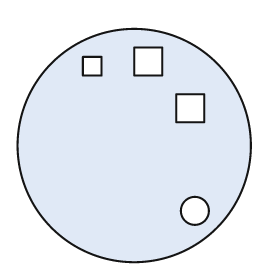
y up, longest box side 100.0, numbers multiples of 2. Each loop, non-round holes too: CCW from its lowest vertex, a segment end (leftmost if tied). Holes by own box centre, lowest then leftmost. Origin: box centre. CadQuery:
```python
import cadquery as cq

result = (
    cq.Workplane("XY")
    .moveTo(0.0, 0.0)
    .circle(50.0)
    .moveTo(26.0, -28.0)
    .circle(6.0)
    .moveTo(18.0, 10.0)
    .lineTo(30.0, 10.0)
    .lineTo(30.0, 22.0)
    .lineTo(18.0, 22.0)
    .close()
    .moveTo(-22.0, 30.0)
    .lineTo(-14.0, 30.0)
    .lineTo(-14.0, 38.0)
    .lineTo(-22.0, 38.0)
    .close()
    .moveTo(0.0, 30.0)
    .lineTo(12.0, 30.0)
    .lineTo(12.0, 42.0)
    .lineTo(0.0, 42.0)
    .close()
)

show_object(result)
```